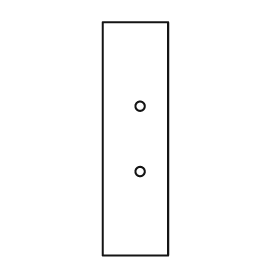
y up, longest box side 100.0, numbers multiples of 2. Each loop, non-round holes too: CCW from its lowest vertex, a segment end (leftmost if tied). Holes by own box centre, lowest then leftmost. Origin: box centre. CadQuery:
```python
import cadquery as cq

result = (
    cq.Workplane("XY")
    .moveTo(-14.0, -50.0)
    .lineTo(14.0, -50.0)
    .lineTo(14.0, 50.0)
    .lineTo(-14.0, 50.0)
    .close()
    .moveTo(2.0, -14.0)
    .circle(2.0)
    .moveTo(2.0, 14.0)
    .circle(2.0)
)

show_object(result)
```